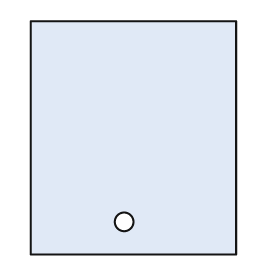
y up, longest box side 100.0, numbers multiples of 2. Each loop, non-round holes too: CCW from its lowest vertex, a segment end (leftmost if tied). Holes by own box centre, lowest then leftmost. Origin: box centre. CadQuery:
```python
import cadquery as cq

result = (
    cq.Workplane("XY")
    .moveTo(-44.0, -50.0)
    .lineTo(44.0, -50.0)
    .lineTo(44.0, 50.0)
    .lineTo(-44.0, 50.0)
    .close()
    .moveTo(-4.0, -36.0)
    .circle(4.0)
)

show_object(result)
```